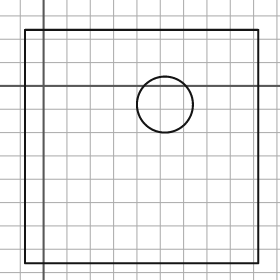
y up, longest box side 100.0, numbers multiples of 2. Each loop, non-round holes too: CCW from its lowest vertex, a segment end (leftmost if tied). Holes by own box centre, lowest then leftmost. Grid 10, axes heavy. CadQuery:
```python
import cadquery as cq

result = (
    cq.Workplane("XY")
    .moveTo(-8.0, -76.0)
    .lineTo(92.0, -76.0)
    .lineTo(92.0, 24.0)
    .lineTo(-8.0, 24.0)
    .close()
    .moveTo(52.0, -8.0)
    .circle(12.0)
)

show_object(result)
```